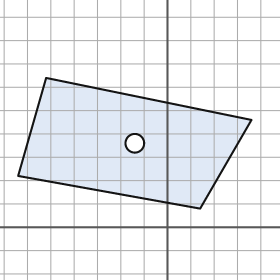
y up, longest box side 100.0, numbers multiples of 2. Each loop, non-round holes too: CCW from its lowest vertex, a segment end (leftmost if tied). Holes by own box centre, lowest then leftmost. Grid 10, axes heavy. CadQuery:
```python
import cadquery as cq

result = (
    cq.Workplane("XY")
    .moveTo(14.0, 8.0)
    .lineTo(36.0, 46.0)
    .lineTo(-52.0, 64.0)
    .lineTo(-64.0, 22.0)
    .close()
    .moveTo(-14.0, 36.0)
    .circle(4.0)
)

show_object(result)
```